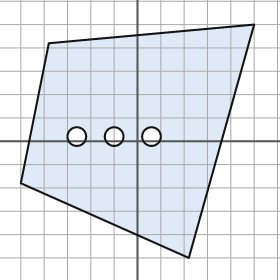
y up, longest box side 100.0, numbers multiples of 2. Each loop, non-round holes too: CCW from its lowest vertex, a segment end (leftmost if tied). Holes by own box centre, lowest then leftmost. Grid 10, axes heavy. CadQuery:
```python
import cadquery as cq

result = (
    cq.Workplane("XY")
    .moveTo(22.0, -50.0)
    .lineTo(50.0, 50.0)
    .lineTo(-38.0, 42.0)
    .lineTo(-50.0, -18.0)
    .close()
    .moveTo(-26.0, 2.0)
    .circle(4.0)
    .moveTo(-10.0, 2.0)
    .circle(4.0)
    .moveTo(6.0, 2.0)
    .circle(4.0)
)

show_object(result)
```